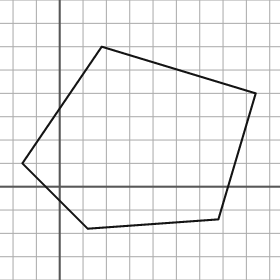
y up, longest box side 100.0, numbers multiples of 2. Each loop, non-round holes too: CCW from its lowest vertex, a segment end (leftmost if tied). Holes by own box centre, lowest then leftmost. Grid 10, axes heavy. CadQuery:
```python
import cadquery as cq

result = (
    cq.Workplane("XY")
    .moveTo(12.0, -18.0)
    .lineTo(68.0, -14.0)
    .lineTo(84.0, 40.0)
    .lineTo(18.0, 60.0)
    .lineTo(-16.0, 10.0)
    .close()
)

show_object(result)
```